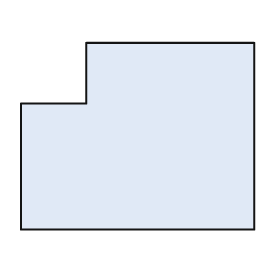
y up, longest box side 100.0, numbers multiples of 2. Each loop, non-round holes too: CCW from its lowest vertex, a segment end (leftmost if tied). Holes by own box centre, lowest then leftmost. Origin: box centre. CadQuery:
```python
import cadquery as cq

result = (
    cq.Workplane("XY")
    .moveTo(-50.0, -40.0)
    .lineTo(50.0, -40.0)
    .lineTo(50.0, 40.0)
    .lineTo(-22.0, 40.0)
    .lineTo(-22.0, 14.0)
    .lineTo(-50.0, 14.0)
    .close()
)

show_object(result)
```